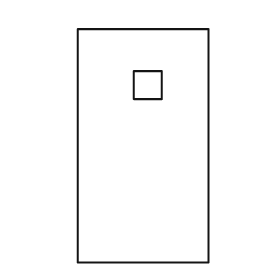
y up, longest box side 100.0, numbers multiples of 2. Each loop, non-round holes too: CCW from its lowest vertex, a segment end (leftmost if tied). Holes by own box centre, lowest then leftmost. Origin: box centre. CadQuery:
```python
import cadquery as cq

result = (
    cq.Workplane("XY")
    .moveTo(-28.0, -50.0)
    .lineTo(28.0, -50.0)
    .lineTo(28.0, 50.0)
    .lineTo(-28.0, 50.0)
    .close()
    .moveTo(-4.0, 20.0)
    .lineTo(8.0, 20.0)
    .lineTo(8.0, 32.0)
    .lineTo(-4.0, 32.0)
    .close()
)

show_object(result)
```